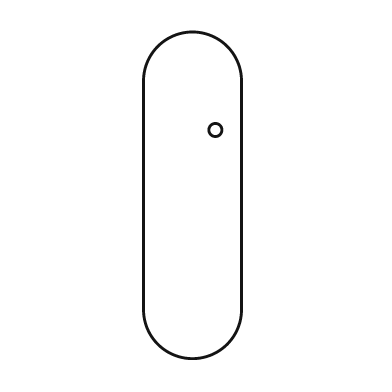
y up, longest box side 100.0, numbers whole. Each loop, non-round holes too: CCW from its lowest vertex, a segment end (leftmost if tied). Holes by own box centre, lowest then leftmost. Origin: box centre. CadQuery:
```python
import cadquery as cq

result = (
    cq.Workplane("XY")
    .moveTo(-15.0, -35.0)
    .threePointArc((0.0, -50.0), (15.0, -35.0))
    .lineTo(15.0, 35.0)
    .threePointArc((0.0, 50.0), (-15.0, 35.0))
    .close()
    .moveTo(7.0, 20.0)
    .circle(2.0)
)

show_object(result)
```